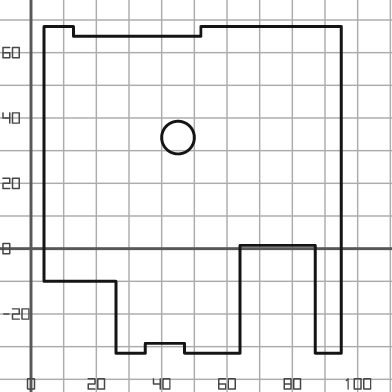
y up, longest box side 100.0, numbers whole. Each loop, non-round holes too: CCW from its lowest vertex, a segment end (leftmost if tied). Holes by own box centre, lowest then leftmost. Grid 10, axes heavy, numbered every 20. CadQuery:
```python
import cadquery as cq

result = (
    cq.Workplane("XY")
    .moveTo(26.0, -32.0)
    .lineTo(35.0, -32.0)
    .lineTo(35.0, -29.0)
    .lineTo(47.0, -29.0)
    .lineTo(47.0, -32.0)
    .lineTo(64.0, -32.0)
    .lineTo(64.0, 1.0)
    .lineTo(87.0, 1.0)
    .lineTo(87.0, -32.0)
    .lineTo(95.0, -32.0)
    .lineTo(95.0, 68.0)
    .lineTo(52.0, 68.0)
    .lineTo(52.0, 65.0)
    .lineTo(13.0, 65.0)
    .lineTo(13.0, 68.0)
    .lineTo(4.0, 68.0)
    .lineTo(4.0, -10.0)
    .lineTo(26.0, -10.0)
    .close()
    .moveTo(45.0, 34.0)
    .circle(5.0)
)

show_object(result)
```